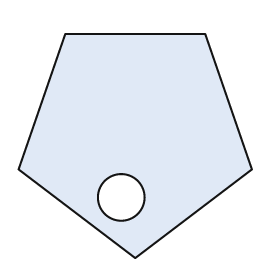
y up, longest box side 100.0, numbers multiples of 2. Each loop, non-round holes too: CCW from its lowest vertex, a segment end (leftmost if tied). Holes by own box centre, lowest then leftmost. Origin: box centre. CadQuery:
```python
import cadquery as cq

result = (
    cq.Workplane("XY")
    .moveTo(0.0, -48.0)
    .lineTo(50.0, -10.0)
    .lineTo(30.0, 48.0)
    .lineTo(-30.0, 48.0)
    .lineTo(-50.0, -10.0)
    .close()
    .moveTo(-6.0, -22.0)
    .circle(10.0)
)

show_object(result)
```